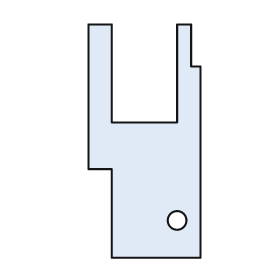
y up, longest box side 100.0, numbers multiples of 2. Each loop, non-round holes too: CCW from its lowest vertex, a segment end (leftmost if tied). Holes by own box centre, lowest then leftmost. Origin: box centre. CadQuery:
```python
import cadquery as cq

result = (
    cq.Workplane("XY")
    .moveTo(-14.0, -50.0)
    .lineTo(24.0, -50.0)
    .lineTo(24.0, 32.0)
    .lineTo(20.0, 32.0)
    .lineTo(20.0, 50.0)
    .lineTo(14.0, 50.0)
    .lineTo(14.0, 8.0)
    .lineTo(-14.0, 8.0)
    .lineTo(-14.0, 50.0)
    .lineTo(-24.0, 50.0)
    .lineTo(-24.0, -12.0)
    .lineTo(-14.0, -12.0)
    .close()
    .moveTo(14.0, -34.0)
    .circle(4.0)
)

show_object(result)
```